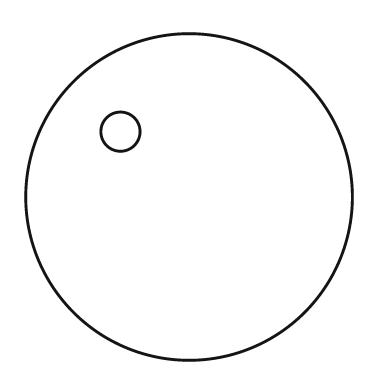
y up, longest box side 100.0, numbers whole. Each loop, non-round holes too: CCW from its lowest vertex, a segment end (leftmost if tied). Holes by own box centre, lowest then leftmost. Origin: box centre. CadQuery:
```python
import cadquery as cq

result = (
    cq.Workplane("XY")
    .moveTo(0.0, 0.0)
    .circle(50.0)
    .moveTo(-21.0, 20.0)
    .circle(6.0)
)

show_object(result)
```